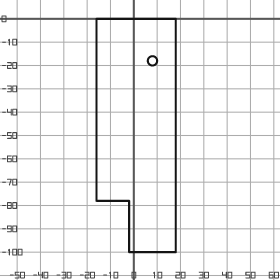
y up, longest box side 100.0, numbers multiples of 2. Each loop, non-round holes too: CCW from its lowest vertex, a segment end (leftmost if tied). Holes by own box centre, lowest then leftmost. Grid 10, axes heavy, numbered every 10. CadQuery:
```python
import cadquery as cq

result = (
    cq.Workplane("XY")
    .moveTo(-2.0, -100.0)
    .lineTo(18.0, -100.0)
    .lineTo(18.0, 0.0)
    .lineTo(-16.0, 0.0)
    .lineTo(-16.0, -78.0)
    .lineTo(-2.0, -78.0)
    .close()
    .moveTo(8.0, -18.0)
    .circle(2.0)
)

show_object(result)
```